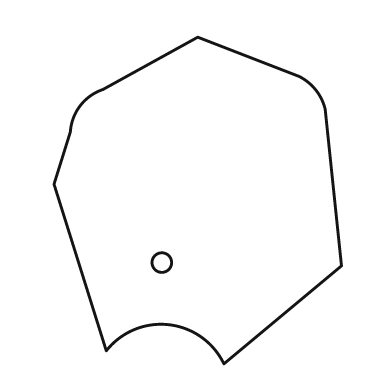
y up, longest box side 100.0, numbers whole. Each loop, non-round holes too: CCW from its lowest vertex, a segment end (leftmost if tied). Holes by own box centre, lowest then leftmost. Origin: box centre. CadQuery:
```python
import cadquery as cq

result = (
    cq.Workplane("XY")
    .moveTo(8.0, -50.0)
    .lineTo(44.0, -20.0)
    .lineTo(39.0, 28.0)
    .threePointArc((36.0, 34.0), (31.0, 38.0))
    .lineTo(0.0, 50.0)
    .lineTo(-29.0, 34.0)
    .threePointArc((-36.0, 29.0), (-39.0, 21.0))
    .lineTo(-44.0, 5.0)
    .lineTo(-28.0, -46.0)
    .threePointArc((-9.0, -38.0), (8.0, -50.0))
    .close()
    .moveTo(-11.0, -19.0)
    .circle(3.0)
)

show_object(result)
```